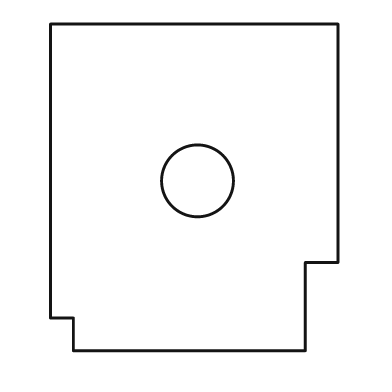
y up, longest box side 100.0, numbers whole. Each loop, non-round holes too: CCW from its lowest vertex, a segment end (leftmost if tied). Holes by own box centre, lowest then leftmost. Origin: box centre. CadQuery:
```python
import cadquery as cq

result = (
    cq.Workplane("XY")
    .moveTo(-37.0, -50.0)
    .lineTo(34.0, -50.0)
    .lineTo(34.0, -23.0)
    .lineTo(44.0, -23.0)
    .lineTo(44.0, 50.0)
    .lineTo(-44.0, 50.0)
    .lineTo(-44.0, -40.0)
    .lineTo(-37.0, -40.0)
    .close()
    .moveTo(1.0, 2.0)
    .circle(11.0)
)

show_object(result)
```